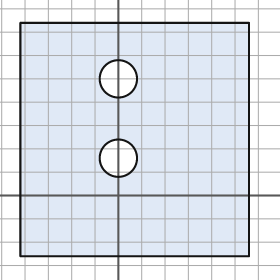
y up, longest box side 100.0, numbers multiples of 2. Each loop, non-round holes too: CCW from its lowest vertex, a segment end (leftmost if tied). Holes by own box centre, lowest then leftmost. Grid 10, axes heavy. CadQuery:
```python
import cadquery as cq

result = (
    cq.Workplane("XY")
    .moveTo(-42.0, -26.0)
    .lineTo(56.0, -26.0)
    .lineTo(56.0, 74.0)
    .lineTo(-42.0, 74.0)
    .close()
    .moveTo(0.0, 16.0)
    .circle(8.0)
    .moveTo(0.0, 50.0)
    .circle(8.0)
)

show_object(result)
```